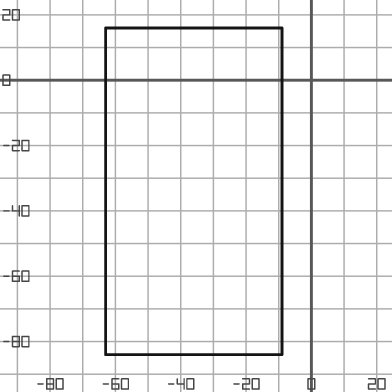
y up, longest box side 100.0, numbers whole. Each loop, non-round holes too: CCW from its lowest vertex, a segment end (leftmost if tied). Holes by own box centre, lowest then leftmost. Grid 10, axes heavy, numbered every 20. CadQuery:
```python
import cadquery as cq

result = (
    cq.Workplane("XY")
    .moveTo(-63.0, -84.0)
    .lineTo(-9.0, -84.0)
    .lineTo(-9.0, 16.0)
    .lineTo(-63.0, 16.0)
    .close()
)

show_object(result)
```